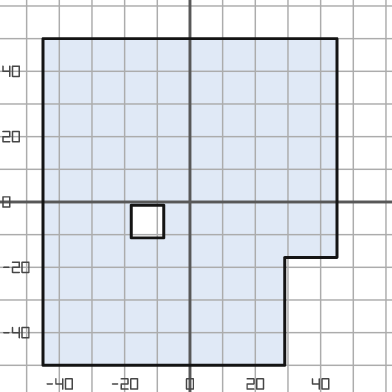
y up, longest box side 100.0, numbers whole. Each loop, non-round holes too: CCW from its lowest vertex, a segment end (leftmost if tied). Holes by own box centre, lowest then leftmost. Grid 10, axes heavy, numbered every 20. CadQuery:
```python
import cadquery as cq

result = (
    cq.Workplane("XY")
    .moveTo(-45.0, -50.0)
    .lineTo(29.0, -50.0)
    .lineTo(29.0, -17.0)
    .lineTo(45.0, -17.0)
    .lineTo(45.0, 50.0)
    .lineTo(-45.0, 50.0)
    .close()
    .moveTo(-18.0, -11.0)
    .lineTo(-8.0, -11.0)
    .lineTo(-8.0, -1.0)
    .lineTo(-18.0, -1.0)
    .close()
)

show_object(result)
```